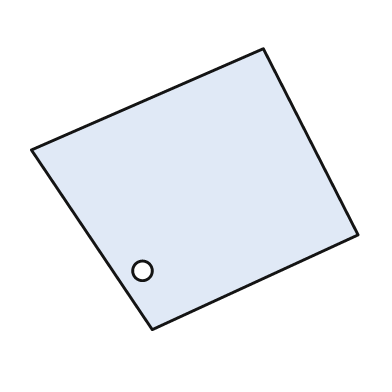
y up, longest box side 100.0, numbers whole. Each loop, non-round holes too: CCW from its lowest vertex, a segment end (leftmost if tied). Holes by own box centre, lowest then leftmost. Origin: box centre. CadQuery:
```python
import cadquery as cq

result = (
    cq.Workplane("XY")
    .moveTo(-13.0, -43.0)
    .lineTo(50.0, -14.0)
    .lineTo(21.0, 43.0)
    .lineTo(-50.0, 12.0)
    .close()
    .moveTo(-16.0, -25.0)
    .circle(3.0)
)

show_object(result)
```